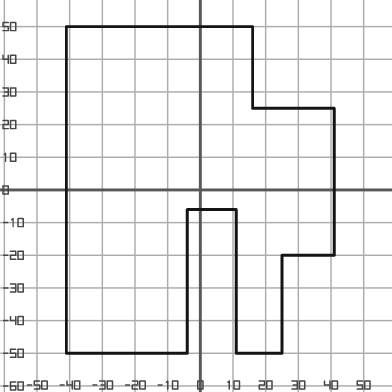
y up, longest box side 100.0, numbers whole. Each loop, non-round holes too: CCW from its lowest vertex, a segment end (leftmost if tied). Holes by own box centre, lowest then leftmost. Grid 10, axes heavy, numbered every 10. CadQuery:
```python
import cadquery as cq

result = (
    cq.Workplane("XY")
    .moveTo(-41.0, -50.0)
    .lineTo(-4.0, -50.0)
    .lineTo(-4.0, -6.0)
    .lineTo(11.0, -6.0)
    .lineTo(11.0, -50.0)
    .lineTo(25.0, -50.0)
    .lineTo(25.0, -20.0)
    .lineTo(41.0, -20.0)
    .lineTo(41.0, 25.0)
    .lineTo(16.0, 25.0)
    .lineTo(16.0, 50.0)
    .lineTo(-41.0, 50.0)
    .close()
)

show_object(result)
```